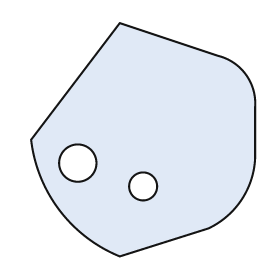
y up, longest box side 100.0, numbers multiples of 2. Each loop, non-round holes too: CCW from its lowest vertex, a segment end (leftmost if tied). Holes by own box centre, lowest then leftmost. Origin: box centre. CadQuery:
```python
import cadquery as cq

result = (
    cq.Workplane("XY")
    .moveTo(-10.0, -50.0)
    .lineTo(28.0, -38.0)
    .threePointArc((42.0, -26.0), (48.0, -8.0))
    .lineTo(48.0, 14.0)
    .threePointArc((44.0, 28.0), (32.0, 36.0))
    .lineTo(-10.0, 50.0)
    .lineTo(-48.0, 0.0)
    .threePointArc((-36.0, -30.0), (-10.0, -50.0))
    .close()
    .moveTo(0.0, -20.0)
    .circle(6.0)
    .moveTo(-28.0, -10.0)
    .circle(8.0)
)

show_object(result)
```